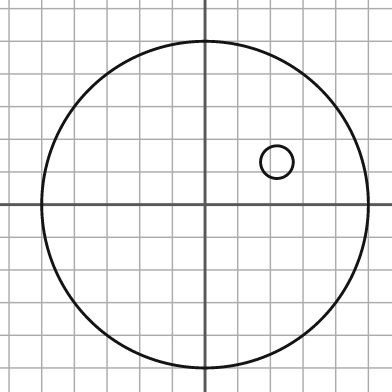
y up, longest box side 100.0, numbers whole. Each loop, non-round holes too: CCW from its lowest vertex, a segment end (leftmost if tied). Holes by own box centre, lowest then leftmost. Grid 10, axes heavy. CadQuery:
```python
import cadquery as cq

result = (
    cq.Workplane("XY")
    .moveTo(0.0, 0.0)
    .circle(50.0)
    .moveTo(22.0, 13.0)
    .circle(5.0)
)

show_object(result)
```